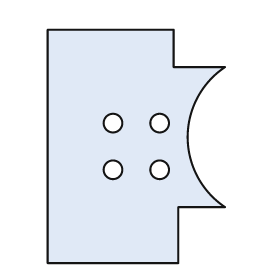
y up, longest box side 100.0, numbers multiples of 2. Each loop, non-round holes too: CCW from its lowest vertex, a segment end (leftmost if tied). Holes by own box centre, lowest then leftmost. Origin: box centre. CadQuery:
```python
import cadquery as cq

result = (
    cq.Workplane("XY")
    .moveTo(-38.0, -50.0)
    .lineTo(18.0, -50.0)
    .lineTo(18.0, -26.0)
    .lineTo(38.0, -26.0)
    .threePointArc((22.0, 4.0), (38.0, 34.0))
    .lineTo(16.0, 34.0)
    .lineTo(16.0, 50.0)
    .lineTo(-38.0, 50.0)
    .close()
    .moveTo(-10.0, -10.0)
    .circle(4.0)
    .moveTo(10.0, -10.0)
    .circle(4.0)
    .moveTo(-10.0, 10.0)
    .circle(4.0)
    .moveTo(10.0, 10.0)
    .circle(4.0)
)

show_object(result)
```